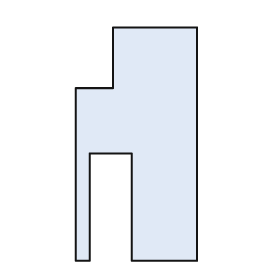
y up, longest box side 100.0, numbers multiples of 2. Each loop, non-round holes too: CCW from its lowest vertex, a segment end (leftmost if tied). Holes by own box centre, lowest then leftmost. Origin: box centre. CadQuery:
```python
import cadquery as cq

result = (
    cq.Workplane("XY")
    .moveTo(-26.0, -50.0)
    .lineTo(-20.0, -50.0)
    .lineTo(-20.0, -4.0)
    .lineTo(-2.0, -4.0)
    .lineTo(-2.0, -50.0)
    .lineTo(26.0, -50.0)
    .lineTo(26.0, 50.0)
    .lineTo(-10.0, 50.0)
    .lineTo(-10.0, 24.0)
    .lineTo(-26.0, 24.0)
    .close()
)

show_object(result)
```